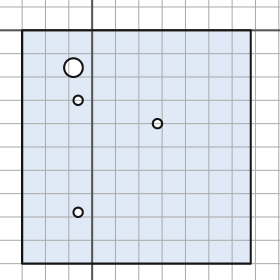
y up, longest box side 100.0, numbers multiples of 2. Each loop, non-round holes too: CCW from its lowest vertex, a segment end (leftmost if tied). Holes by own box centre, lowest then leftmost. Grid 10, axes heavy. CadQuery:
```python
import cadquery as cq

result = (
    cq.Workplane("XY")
    .moveTo(-30.0, -100.0)
    .lineTo(68.0, -100.0)
    .lineTo(68.0, 0.0)
    .lineTo(-30.0, 0.0)
    .close()
    .moveTo(-6.0, -78.0)
    .circle(2.0)
    .moveTo(28.0, -40.0)
    .circle(2.0)
    .moveTo(-6.0, -30.0)
    .circle(2.0)
    .moveTo(-8.0, -16.0)
    .circle(4.0)
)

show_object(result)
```